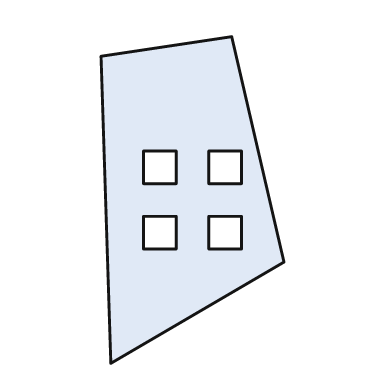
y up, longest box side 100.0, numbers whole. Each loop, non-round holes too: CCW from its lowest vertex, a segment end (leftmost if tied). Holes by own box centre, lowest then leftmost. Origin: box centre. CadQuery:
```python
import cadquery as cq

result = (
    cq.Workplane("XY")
    .moveTo(-25.0, -50.0)
    .lineTo(28.0, -19.0)
    .lineTo(12.0, 50.0)
    .lineTo(-28.0, 44.0)
    .close()
    .moveTo(-15.0, -15.0)
    .lineTo(-5.0, -15.0)
    .lineTo(-5.0, -5.0)
    .lineTo(-15.0, -5.0)
    .close()
    .moveTo(5.0, -15.0)
    .lineTo(15.0, -15.0)
    .lineTo(15.0, -5.0)
    .lineTo(5.0, -5.0)
    .close()
    .moveTo(-15.0, 5.0)
    .lineTo(-5.0, 5.0)
    .lineTo(-5.0, 15.0)
    .lineTo(-15.0, 15.0)
    .close()
    .moveTo(5.0, 5.0)
    .lineTo(15.0, 5.0)
    .lineTo(15.0, 15.0)
    .lineTo(5.0, 15.0)
    .close()
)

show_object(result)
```